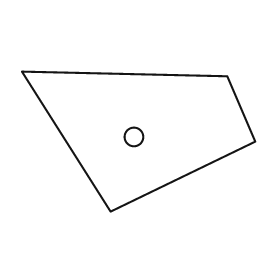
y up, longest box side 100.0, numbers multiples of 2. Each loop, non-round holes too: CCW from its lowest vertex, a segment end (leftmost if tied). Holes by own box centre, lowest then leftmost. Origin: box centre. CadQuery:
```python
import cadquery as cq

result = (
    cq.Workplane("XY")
    .moveTo(-12.0, -30.0)
    .lineTo(50.0, 0.0)
    .lineTo(38.0, 28.0)
    .lineTo(-50.0, 30.0)
    .close()
    .moveTo(-2.0, 2.0)
    .circle(4.0)
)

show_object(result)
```